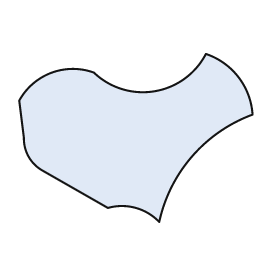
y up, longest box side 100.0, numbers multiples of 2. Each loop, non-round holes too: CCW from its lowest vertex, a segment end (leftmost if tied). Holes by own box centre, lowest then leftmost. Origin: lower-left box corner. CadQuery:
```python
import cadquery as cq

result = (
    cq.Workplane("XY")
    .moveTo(60.0, 0.0)
    .threePointArc((74.0, 28.0), (100.0, 46.0))
    .threePointArc((94.0, 62.0), (80.0, 72.0))
    .threePointArc((58.0, 56.0), (32.0, 64.0))
    .threePointArc((14.0, 64.0), (0.0, 52.0))
    .lineTo(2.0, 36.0)
    .threePointArc((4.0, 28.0), (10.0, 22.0))
    .lineTo(38.0, 6.0)
    .threePointArc((50.0, 6.0), (60.0, 0.0))
    .close()
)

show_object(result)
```